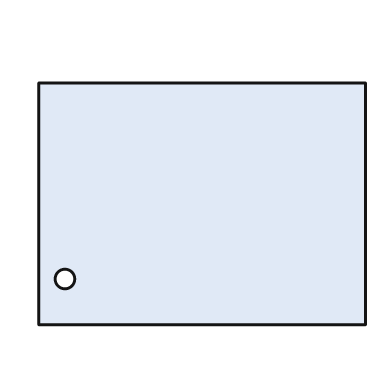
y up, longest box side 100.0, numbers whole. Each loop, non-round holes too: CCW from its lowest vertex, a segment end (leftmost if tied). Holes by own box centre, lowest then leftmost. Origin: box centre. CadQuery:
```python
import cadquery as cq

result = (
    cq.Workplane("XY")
    .moveTo(-50.0, -37.0)
    .lineTo(50.0, -37.0)
    .lineTo(50.0, 37.0)
    .lineTo(-50.0, 37.0)
    .close()
    .moveTo(-42.0, -23.0)
    .circle(3.0)
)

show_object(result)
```